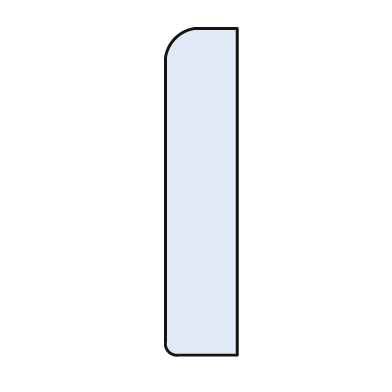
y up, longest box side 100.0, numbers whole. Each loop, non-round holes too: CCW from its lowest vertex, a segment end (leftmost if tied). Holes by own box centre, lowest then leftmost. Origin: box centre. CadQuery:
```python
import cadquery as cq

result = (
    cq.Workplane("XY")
    .moveTo(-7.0, -50.0)
    .lineTo(11.0, -50.0)
    .lineTo(11.0, 50.0)
    .lineTo(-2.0, 50.0)
    .threePointArc((-8.0, 47.0), (-11.0, 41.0))
    .lineTo(-11.0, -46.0)
    .threePointArc((-10.0, -49.0), (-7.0, -50.0))
    .close()
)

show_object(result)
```